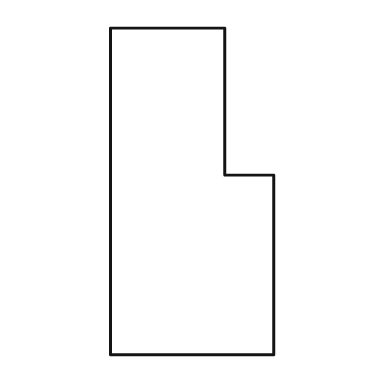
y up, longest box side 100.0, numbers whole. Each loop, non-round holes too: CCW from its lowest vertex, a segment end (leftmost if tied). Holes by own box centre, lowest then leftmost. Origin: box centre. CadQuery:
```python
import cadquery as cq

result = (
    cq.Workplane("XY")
    .moveTo(-25.0, -50.0)
    .lineTo(25.0, -50.0)
    .lineTo(25.0, 5.0)
    .lineTo(10.0, 5.0)
    .lineTo(10.0, 50.0)
    .lineTo(-25.0, 50.0)
    .close()
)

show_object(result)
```